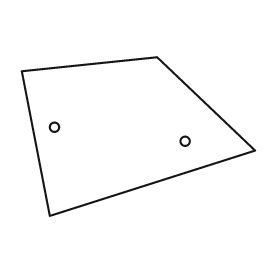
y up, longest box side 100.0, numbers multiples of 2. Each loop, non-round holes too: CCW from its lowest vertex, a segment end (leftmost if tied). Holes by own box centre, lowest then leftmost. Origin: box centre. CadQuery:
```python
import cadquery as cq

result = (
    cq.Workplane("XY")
    .moveTo(-38.0, -34.0)
    .lineTo(50.0, -6.0)
    .lineTo(8.0, 34.0)
    .lineTo(-50.0, 28.0)
    .close()
    .moveTo(20.0, -2.0)
    .circle(2.0)
    .moveTo(-36.0, 4.0)
    .circle(2.0)
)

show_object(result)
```